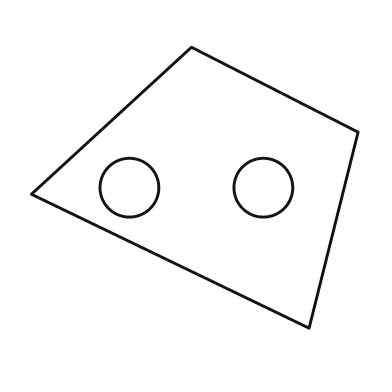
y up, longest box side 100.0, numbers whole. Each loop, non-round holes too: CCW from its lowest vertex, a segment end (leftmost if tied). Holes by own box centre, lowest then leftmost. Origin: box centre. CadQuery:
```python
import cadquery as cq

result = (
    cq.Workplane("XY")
    .moveTo(35.0, -43.0)
    .lineTo(50.0, 17.0)
    .lineTo(-1.0, 43.0)
    .lineTo(-50.0, -2.0)
    .close()
    .moveTo(-20.0, 0.0)
    .circle(9.0)
    .moveTo(21.0, 0.0)
    .circle(9.0)
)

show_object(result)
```